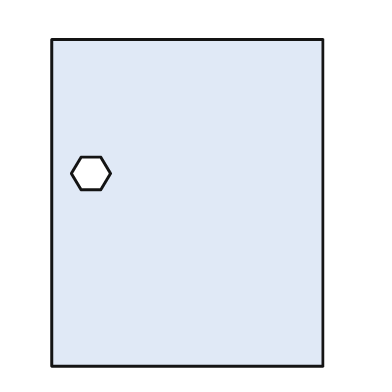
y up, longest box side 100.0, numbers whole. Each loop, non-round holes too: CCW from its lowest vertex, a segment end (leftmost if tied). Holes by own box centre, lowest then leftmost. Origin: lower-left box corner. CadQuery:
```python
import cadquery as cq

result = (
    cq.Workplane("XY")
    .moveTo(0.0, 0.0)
    .lineTo(83.0, 0.0)
    .lineTo(83.0, 100.0)
    .lineTo(0.0, 100.0)
    .close()
    .moveTo(9.0, 54.0)
    .lineTo(15.0, 54.0)
    .lineTo(18.0, 59.0)
    .lineTo(15.0, 64.0)
    .lineTo(9.0, 64.0)
    .lineTo(6.0, 59.0)
    .close()
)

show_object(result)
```